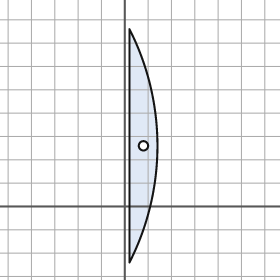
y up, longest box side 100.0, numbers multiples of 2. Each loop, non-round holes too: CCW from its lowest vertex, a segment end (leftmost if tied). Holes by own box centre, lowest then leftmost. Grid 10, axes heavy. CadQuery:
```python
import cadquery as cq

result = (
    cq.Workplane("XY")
    .moveTo(2.0, -24.0)
    .threePointArc((14.0, 26.0), (2.0, 76.0))
    .close()
    .moveTo(8.0, 26.0)
    .circle(2.0)
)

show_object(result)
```